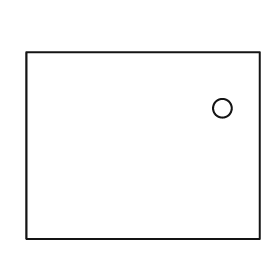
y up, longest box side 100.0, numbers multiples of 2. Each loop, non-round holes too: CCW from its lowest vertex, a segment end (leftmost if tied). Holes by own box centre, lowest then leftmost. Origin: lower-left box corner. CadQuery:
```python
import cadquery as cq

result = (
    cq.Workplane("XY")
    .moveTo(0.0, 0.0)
    .lineTo(100.0, 0.0)
    .lineTo(100.0, 80.0)
    .lineTo(0.0, 80.0)
    .close()
    .moveTo(84.0, 56.0)
    .circle(4.0)
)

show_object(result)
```